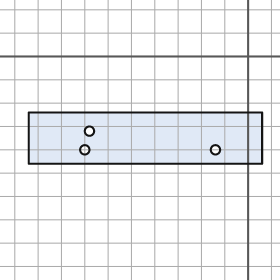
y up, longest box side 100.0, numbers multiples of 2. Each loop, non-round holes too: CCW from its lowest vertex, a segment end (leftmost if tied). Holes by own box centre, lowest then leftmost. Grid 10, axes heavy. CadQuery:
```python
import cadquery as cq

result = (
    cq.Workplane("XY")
    .moveTo(-94.0, -46.0)
    .lineTo(6.0, -46.0)
    .lineTo(6.0, -24.0)
    .lineTo(-94.0, -24.0)
    .close()
    .moveTo(-70.0, -40.0)
    .circle(2.0)
    .moveTo(-14.0, -40.0)
    .circle(2.0)
    .moveTo(-68.0, -32.0)
    .circle(2.0)
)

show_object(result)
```